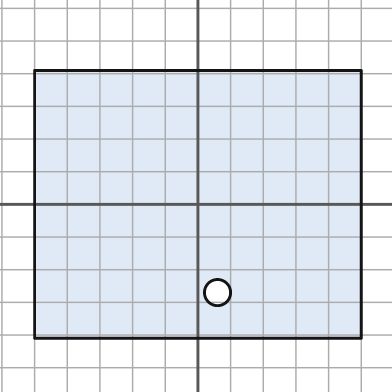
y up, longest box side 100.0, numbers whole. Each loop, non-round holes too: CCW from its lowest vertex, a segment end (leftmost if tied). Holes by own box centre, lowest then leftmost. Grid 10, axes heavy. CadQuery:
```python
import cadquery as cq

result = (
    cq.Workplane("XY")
    .moveTo(-50.0, -41.0)
    .lineTo(50.0, -41.0)
    .lineTo(50.0, 41.0)
    .lineTo(-50.0, 41.0)
    .close()
    .moveTo(6.0, -27.0)
    .circle(4.0)
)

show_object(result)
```